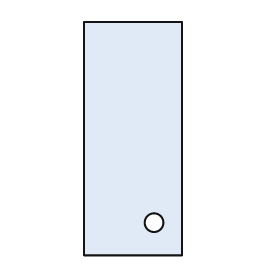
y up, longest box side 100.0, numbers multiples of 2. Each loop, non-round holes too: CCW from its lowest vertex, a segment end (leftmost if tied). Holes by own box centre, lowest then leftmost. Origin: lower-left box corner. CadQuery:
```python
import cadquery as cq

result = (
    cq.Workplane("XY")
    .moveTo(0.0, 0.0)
    .lineTo(42.0, 0.0)
    .lineTo(42.0, 100.0)
    .lineTo(0.0, 100.0)
    .close()
    .moveTo(30.0, 14.0)
    .circle(4.0)
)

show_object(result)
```